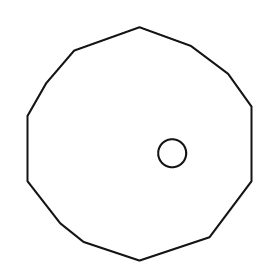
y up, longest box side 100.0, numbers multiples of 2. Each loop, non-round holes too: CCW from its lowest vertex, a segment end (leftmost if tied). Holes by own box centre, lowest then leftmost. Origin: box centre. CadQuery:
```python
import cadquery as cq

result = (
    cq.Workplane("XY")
    .moveTo(0.0, -50.0)
    .lineTo(30.0, -40.0)
    .lineTo(48.0, -16.0)
    .lineTo(48.0, 16.0)
    .lineTo(38.0, 30.0)
    .lineTo(22.0, 42.0)
    .lineTo(0.0, 50.0)
    .lineTo(-28.0, 40.0)
    .lineTo(-40.0, 26.0)
    .lineTo(-48.0, 12.0)
    .lineTo(-48.0, -16.0)
    .lineTo(-34.0, -34.0)
    .lineTo(-24.0, -42.0)
    .close()
    .moveTo(14.0, -4.0)
    .circle(6.0)
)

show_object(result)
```